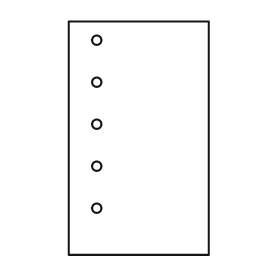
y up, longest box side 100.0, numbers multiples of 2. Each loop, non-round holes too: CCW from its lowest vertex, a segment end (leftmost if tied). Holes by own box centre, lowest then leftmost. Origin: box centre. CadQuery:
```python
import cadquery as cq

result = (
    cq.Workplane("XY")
    .moveTo(-30.0, -50.0)
    .lineTo(30.0, -50.0)
    .lineTo(30.0, 50.0)
    .lineTo(-30.0, 50.0)
    .close()
    .moveTo(-18.0, -30.0)
    .circle(2.0)
    .moveTo(-18.0, -12.0)
    .circle(2.0)
    .moveTo(-18.0, 6.0)
    .circle(2.0)
    .moveTo(-18.0, 24.0)
    .circle(2.0)
    .moveTo(-18.0, 42.0)
    .circle(2.0)
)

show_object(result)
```